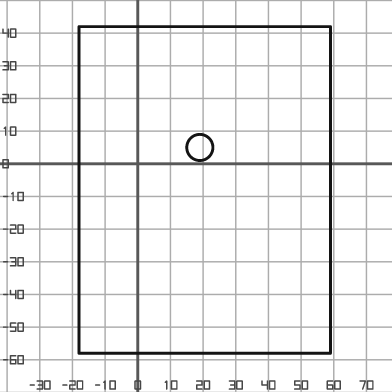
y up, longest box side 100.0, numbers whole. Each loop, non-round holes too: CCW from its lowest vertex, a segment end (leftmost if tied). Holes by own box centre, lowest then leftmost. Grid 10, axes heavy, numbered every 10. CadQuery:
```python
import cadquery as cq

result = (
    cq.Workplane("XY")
    .moveTo(-18.0, -58.0)
    .lineTo(59.0, -58.0)
    .lineTo(59.0, 42.0)
    .lineTo(-18.0, 42.0)
    .close()
    .moveTo(19.0, 5.0)
    .circle(4.0)
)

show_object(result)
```